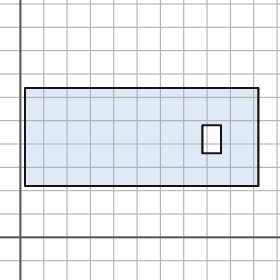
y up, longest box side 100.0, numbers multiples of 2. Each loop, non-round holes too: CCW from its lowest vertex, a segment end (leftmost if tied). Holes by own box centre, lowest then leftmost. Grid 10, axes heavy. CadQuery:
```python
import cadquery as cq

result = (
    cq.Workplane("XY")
    .moveTo(2.0, 22.0)
    .lineTo(102.0, 22.0)
    .lineTo(102.0, 64.0)
    .lineTo(2.0, 64.0)
    .close()
    .moveTo(78.0, 36.0)
    .lineTo(86.0, 36.0)
    .lineTo(86.0, 48.0)
    .lineTo(78.0, 48.0)
    .close()
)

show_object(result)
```